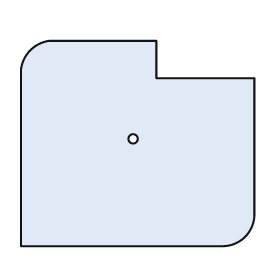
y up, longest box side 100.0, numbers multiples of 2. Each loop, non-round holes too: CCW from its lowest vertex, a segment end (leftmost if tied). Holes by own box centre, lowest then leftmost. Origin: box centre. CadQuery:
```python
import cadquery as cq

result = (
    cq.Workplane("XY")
    .moveTo(-50.0, -44.0)
    .lineTo(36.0, -44.0)
    .threePointArc((46.0, -40.0), (50.0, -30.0))
    .lineTo(50.0, 28.0)
    .lineTo(8.0, 28.0)
    .lineTo(8.0, 44.0)
    .lineTo(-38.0, 44.0)
    .threePointArc((-46.0, 40.0), (-50.0, 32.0))
    .close()
    .moveTo(-2.0, 2.0)
    .circle(2.0)
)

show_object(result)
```